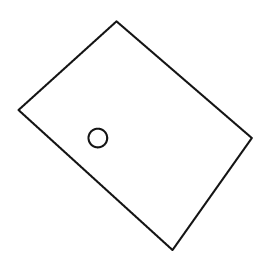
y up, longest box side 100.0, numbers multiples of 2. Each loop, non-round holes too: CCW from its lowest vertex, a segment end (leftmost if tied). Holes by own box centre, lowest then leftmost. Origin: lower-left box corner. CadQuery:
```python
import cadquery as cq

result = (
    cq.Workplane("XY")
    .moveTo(66.0, 0.0)
    .lineTo(100.0, 48.0)
    .lineTo(42.0, 98.0)
    .lineTo(0.0, 60.0)
    .close()
    .moveTo(34.0, 48.0)
    .circle(4.0)
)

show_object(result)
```